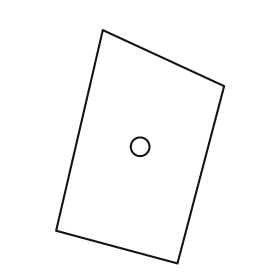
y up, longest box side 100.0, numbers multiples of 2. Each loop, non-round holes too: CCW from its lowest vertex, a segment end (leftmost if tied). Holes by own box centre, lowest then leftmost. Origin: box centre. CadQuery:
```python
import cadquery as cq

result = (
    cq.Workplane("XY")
    .moveTo(16.0, -50.0)
    .lineTo(36.0, 26.0)
    .lineTo(-16.0, 50.0)
    .lineTo(-36.0, -36.0)
    .close()
    .moveTo(0.0, 0.0)
    .circle(4.0)
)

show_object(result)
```